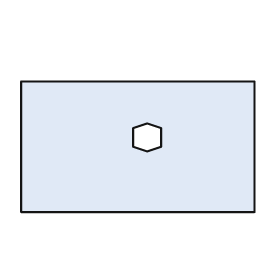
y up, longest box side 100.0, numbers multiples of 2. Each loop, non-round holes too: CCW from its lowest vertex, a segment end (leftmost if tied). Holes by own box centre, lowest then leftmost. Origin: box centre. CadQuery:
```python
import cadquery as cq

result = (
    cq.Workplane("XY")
    .moveTo(-50.0, -28.0)
    .lineTo(50.0, -28.0)
    .lineTo(50.0, 28.0)
    .lineTo(-50.0, 28.0)
    .close()
    .moveTo(4.0, -2.0)
    .lineTo(10.0, 0.0)
    .lineTo(10.0, 8.0)
    .lineTo(4.0, 10.0)
    .lineTo(-2.0, 8.0)
    .lineTo(-2.0, 0.0)
    .close()
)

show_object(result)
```